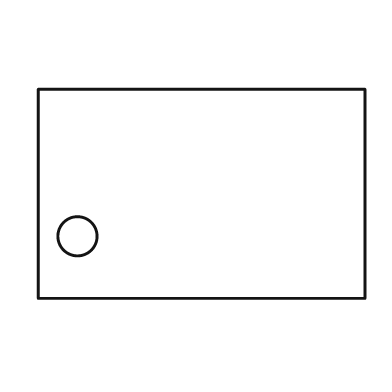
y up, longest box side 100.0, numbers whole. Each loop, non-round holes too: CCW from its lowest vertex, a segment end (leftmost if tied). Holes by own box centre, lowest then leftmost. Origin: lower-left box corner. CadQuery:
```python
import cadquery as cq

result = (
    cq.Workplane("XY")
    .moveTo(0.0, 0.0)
    .lineTo(100.0, 0.0)
    .lineTo(100.0, 64.0)
    .lineTo(0.0, 64.0)
    .close()
    .moveTo(12.0, 19.0)
    .circle(6.0)
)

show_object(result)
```